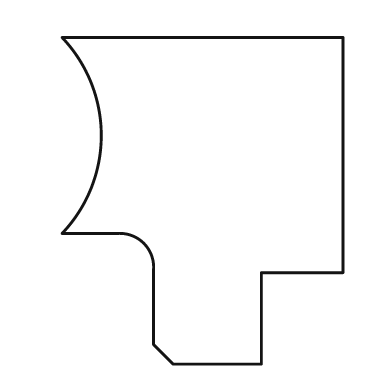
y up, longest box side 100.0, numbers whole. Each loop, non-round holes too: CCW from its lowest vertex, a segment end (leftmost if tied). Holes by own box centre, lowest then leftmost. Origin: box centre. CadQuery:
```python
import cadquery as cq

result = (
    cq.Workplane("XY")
    .moveTo(-9.0, -50.0)
    .lineTo(18.0, -50.0)
    .lineTo(18.0, -22.0)
    .lineTo(43.0, -22.0)
    .lineTo(43.0, 50.0)
    .lineTo(-43.0, 50.0)
    .threePointArc((-31.0, 20.0), (-43.0, -10.0))
    .lineTo(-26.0, -10.0)
    .threePointArc((-18.0, -13.0), (-15.0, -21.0))
    .lineTo(-15.0, -44.0)
    .close()
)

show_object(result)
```